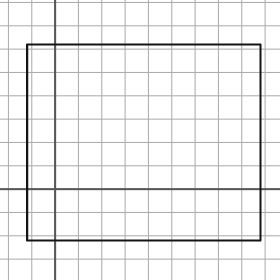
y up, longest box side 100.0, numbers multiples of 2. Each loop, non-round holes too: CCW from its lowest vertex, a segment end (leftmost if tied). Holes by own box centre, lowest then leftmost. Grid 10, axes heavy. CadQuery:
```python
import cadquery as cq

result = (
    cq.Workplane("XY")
    .moveTo(-12.0, -22.0)
    .lineTo(88.0, -22.0)
    .lineTo(88.0, 62.0)
    .lineTo(-12.0, 62.0)
    .close()
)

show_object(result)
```